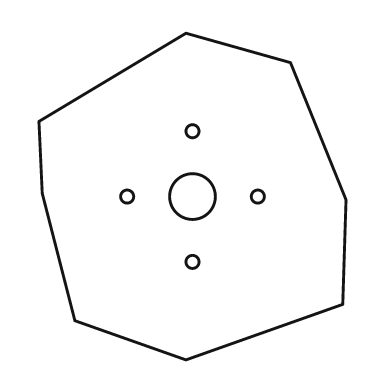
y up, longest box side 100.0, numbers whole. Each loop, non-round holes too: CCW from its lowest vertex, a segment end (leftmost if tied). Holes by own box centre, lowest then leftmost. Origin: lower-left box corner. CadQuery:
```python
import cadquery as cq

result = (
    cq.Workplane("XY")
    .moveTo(45.0, 0.0)
    .lineTo(93.0, 17.0)
    .lineTo(94.0, 49.0)
    .lineTo(77.0, 91.0)
    .lineTo(45.0, 100.0)
    .lineTo(0.0, 73.0)
    .lineTo(1.0, 51.0)
    .lineTo(11.0, 12.0)
    .close()
    .moveTo(47.0, 30.0)
    .circle(2.0)
    .moveTo(27.0, 50.0)
    .circle(2.0)
    .moveTo(47.0, 50.0)
    .circle(7.0)
    .moveTo(67.0, 50.0)
    .circle(2.0)
    .moveTo(47.0, 70.0)
    .circle(2.0)
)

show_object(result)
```